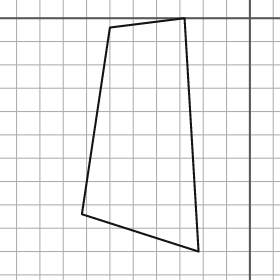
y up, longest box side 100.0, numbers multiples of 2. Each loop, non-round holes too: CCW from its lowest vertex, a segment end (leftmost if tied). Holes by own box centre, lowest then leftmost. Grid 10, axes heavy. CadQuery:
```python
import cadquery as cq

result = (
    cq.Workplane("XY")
    .moveTo(-22.0, -100.0)
    .lineTo(-28.0, 0.0)
    .lineTo(-60.0, -4.0)
    .lineTo(-72.0, -84.0)
    .close()
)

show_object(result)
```